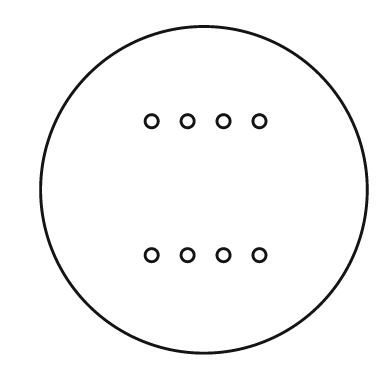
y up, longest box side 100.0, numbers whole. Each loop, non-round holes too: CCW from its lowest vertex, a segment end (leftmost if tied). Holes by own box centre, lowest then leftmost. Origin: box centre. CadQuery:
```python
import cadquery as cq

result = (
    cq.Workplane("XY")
    .moveTo(0.0, 0.0)
    .circle(50.0)
    .moveTo(-16.0, -20.0)
    .circle(2.0)
    .moveTo(-5.0, -20.0)
    .circle(2.0)
    .moveTo(6.0, -20.0)
    .circle(2.0)
    .moveTo(17.0, -20.0)
    .circle(2.0)
    .moveTo(-16.0, 21.0)
    .circle(2.0)
    .moveTo(-5.0, 21.0)
    .circle(2.0)
    .moveTo(6.0, 21.0)
    .circle(2.0)
    .moveTo(17.0, 21.0)
    .circle(2.0)
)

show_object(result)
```